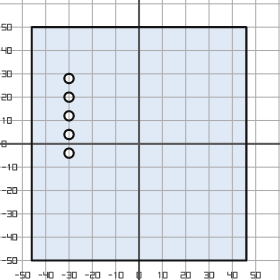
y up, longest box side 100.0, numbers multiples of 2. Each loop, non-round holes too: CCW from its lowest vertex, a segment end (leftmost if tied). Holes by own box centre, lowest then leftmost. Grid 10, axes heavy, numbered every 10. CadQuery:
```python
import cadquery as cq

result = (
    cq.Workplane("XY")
    .moveTo(-46.0, -50.0)
    .lineTo(46.0, -50.0)
    .lineTo(46.0, 50.0)
    .lineTo(-46.0, 50.0)
    .close()
    .moveTo(-30.0, -4.0)
    .circle(2.0)
    .moveTo(-30.0, 4.0)
    .circle(2.0)
    .moveTo(-30.0, 12.0)
    .circle(2.0)
    .moveTo(-30.0, 20.0)
    .circle(2.0)
    .moveTo(-30.0, 28.0)
    .circle(2.0)
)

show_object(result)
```